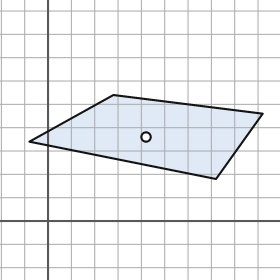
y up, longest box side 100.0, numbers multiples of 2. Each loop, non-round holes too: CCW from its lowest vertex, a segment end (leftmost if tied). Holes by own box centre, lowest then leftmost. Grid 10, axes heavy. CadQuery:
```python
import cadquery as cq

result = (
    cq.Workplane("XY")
    .moveTo(72.0, 18.0)
    .lineTo(92.0, 46.0)
    .lineTo(28.0, 54.0)
    .lineTo(-8.0, 34.0)
    .close()
    .moveTo(42.0, 36.0)
    .circle(2.0)
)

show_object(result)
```